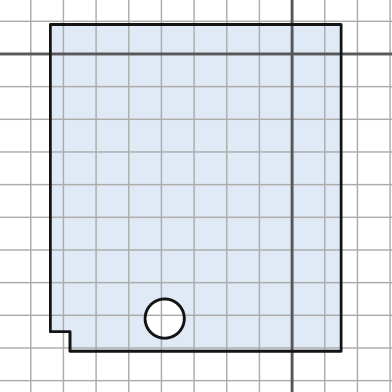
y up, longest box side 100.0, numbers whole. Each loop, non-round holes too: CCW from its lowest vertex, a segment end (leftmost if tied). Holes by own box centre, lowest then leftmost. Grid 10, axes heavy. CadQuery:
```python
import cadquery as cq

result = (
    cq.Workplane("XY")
    .moveTo(-68.0, -91.0)
    .lineTo(15.0, -91.0)
    .lineTo(15.0, 9.0)
    .lineTo(-74.0, 9.0)
    .lineTo(-74.0, -85.0)
    .lineTo(-68.0, -85.0)
    .close()
    .moveTo(-39.0, -81.0)
    .circle(6.0)
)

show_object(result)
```